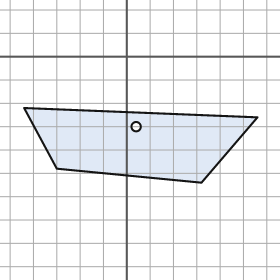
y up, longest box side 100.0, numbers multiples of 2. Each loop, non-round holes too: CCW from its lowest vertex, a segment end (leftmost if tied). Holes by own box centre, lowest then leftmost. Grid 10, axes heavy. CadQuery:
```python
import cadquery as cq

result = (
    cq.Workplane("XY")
    .moveTo(32.0, -54.0)
    .lineTo(56.0, -26.0)
    .lineTo(-44.0, -22.0)
    .lineTo(-30.0, -48.0)
    .close()
    .moveTo(4.0, -30.0)
    .circle(2.0)
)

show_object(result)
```